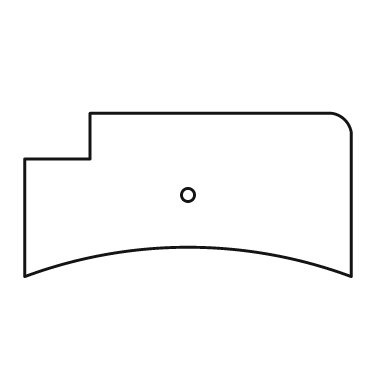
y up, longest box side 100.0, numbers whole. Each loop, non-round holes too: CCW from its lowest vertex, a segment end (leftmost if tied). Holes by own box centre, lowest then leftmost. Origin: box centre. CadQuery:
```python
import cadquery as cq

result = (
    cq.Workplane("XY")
    .moveTo(-50.0, -25.0)
    .threePointArc((0.0, -16.0), (50.0, -25.0))
    .lineTo(50.0, 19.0)
    .threePointArc((48.0, 23.0), (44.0, 25.0))
    .lineTo(-30.0, 25.0)
    .lineTo(-30.0, 11.0)
    .lineTo(-50.0, 11.0)
    .close()
    .moveTo(0.0, 0.0)
    .circle(2.0)
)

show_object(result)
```